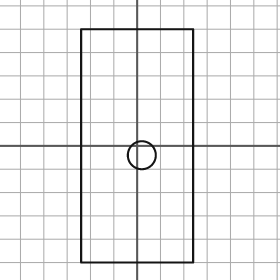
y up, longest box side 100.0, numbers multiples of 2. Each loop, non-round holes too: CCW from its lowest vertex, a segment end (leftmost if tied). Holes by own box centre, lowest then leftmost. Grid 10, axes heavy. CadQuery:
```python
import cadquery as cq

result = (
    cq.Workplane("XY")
    .moveTo(-24.0, -50.0)
    .lineTo(24.0, -50.0)
    .lineTo(24.0, 50.0)
    .lineTo(-24.0, 50.0)
    .close()
    .moveTo(2.0, -4.0)
    .circle(6.0)
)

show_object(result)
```